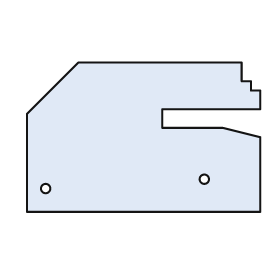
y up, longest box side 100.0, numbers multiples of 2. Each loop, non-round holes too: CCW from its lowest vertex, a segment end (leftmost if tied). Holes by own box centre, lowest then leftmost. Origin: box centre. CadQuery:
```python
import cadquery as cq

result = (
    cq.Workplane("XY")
    .moveTo(-50.0, -32.0)
    .lineTo(50.0, -32.0)
    .lineTo(50.0, 0.0)
    .lineTo(34.0, 4.0)
    .lineTo(8.0, 4.0)
    .lineTo(8.0, 12.0)
    .lineTo(50.0, 12.0)
    .lineTo(50.0, 20.0)
    .lineTo(46.0, 20.0)
    .lineTo(46.0, 24.0)
    .lineTo(42.0, 24.0)
    .lineTo(42.0, 32.0)
    .lineTo(-28.0, 32.0)
    .lineTo(-50.0, 10.0)
    .close()
    .moveTo(-42.0, -22.0)
    .circle(2.0)
    .moveTo(26.0, -18.0)
    .circle(2.0)
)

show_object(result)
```